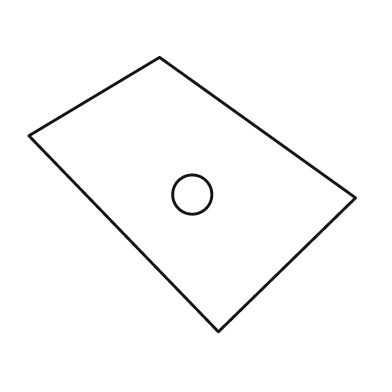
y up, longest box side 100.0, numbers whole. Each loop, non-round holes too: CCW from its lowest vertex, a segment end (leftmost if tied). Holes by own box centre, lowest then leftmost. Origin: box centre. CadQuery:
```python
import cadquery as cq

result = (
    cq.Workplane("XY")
    .moveTo(8.0, -42.0)
    .lineTo(50.0, -1.0)
    .lineTo(-10.0, 42.0)
    .lineTo(-50.0, 18.0)
    .close()
    .moveTo(0.0, 0.0)
    .circle(6.0)
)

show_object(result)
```